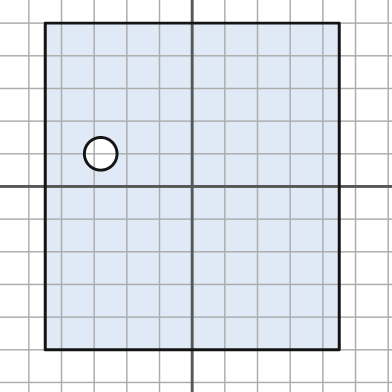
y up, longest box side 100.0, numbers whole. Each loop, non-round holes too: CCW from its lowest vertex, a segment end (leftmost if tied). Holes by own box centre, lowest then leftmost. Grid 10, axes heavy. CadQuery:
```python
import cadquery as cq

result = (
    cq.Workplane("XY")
    .moveTo(-45.0, -50.0)
    .lineTo(45.0, -50.0)
    .lineTo(45.0, 50.0)
    .lineTo(-45.0, 50.0)
    .close()
    .moveTo(-28.0, 10.0)
    .circle(5.0)
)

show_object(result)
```